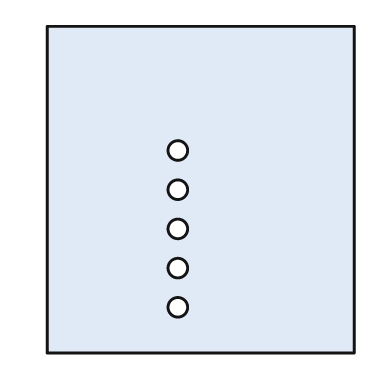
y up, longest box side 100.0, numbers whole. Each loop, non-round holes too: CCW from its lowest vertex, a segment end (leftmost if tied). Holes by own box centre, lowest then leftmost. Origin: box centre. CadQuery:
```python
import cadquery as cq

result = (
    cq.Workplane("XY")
    .moveTo(-47.0, -50.0)
    .lineTo(47.0, -50.0)
    .lineTo(47.0, 50.0)
    .lineTo(-47.0, 50.0)
    .close()
    .moveTo(-7.0, -36.0)
    .circle(3.0)
    .moveTo(-7.0, -24.0)
    .circle(3.0)
    .moveTo(-7.0, -12.0)
    .circle(3.0)
    .moveTo(-7.0, 0.0)
    .circle(3.0)
    .moveTo(-7.0, 12.0)
    .circle(3.0)
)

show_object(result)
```